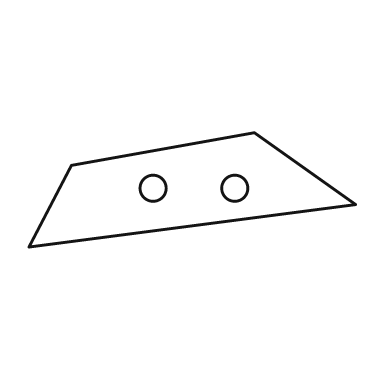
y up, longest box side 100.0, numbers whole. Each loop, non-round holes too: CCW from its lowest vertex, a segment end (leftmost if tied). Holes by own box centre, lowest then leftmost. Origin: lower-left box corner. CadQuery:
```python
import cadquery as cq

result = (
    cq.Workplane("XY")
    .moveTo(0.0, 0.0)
    .lineTo(100.0, 13.0)
    .lineTo(69.0, 35.0)
    .lineTo(13.0, 25.0)
    .close()
    .moveTo(38.0, 18.0)
    .circle(4.0)
    .moveTo(63.0, 18.0)
    .circle(4.0)
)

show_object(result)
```